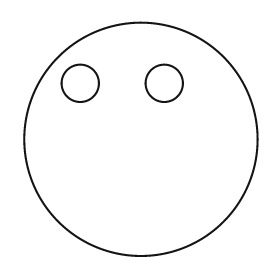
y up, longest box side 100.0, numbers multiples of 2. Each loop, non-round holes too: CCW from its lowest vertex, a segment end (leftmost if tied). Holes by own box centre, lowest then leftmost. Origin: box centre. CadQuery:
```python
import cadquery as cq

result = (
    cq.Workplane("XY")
    .moveTo(0.0, 0.0)
    .circle(50.0)
    .moveTo(-26.0, 24.0)
    .circle(8.0)
    .moveTo(10.0, 24.0)
    .circle(8.0)
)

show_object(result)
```